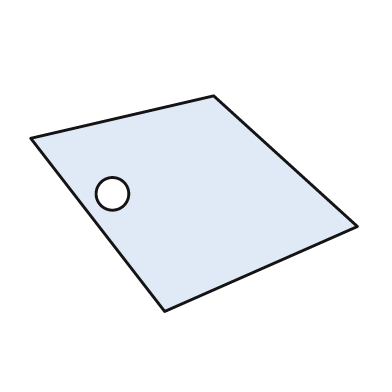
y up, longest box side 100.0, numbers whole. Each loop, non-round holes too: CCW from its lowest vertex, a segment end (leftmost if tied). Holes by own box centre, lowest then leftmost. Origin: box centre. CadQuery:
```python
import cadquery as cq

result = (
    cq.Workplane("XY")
    .moveTo(-9.0, -33.0)
    .lineTo(50.0, -7.0)
    .lineTo(6.0, 33.0)
    .lineTo(-50.0, 20.0)
    .close()
    .moveTo(-25.0, 3.0)
    .circle(5.0)
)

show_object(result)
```